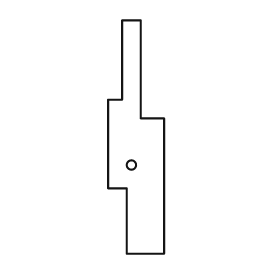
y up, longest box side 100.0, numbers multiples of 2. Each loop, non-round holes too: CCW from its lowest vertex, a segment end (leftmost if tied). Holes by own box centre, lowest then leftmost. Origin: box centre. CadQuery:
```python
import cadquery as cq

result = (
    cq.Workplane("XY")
    .moveTo(-4.0, -50.0)
    .lineTo(12.0, -50.0)
    .lineTo(12.0, 8.0)
    .lineTo(2.0, 8.0)
    .lineTo(2.0, 50.0)
    .lineTo(-6.0, 50.0)
    .lineTo(-6.0, 16.0)
    .lineTo(-12.0, 16.0)
    .lineTo(-12.0, -22.0)
    .lineTo(-4.0, -22.0)
    .close()
    .moveTo(-2.0, -12.0)
    .circle(2.0)
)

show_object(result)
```